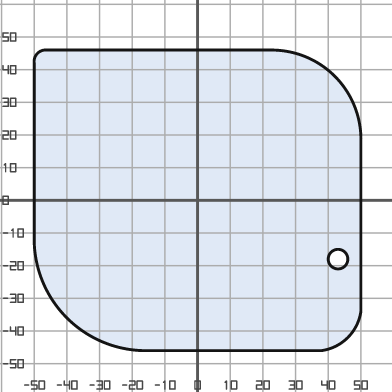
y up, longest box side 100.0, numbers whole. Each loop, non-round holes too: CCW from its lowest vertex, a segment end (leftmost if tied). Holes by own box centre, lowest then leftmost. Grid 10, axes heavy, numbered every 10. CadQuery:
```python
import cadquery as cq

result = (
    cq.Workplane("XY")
    .moveTo(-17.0, -46.0)
    .lineTo(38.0, -46.0)
    .threePointArc((46.0, -42.0), (50.0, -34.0))
    .lineTo(50.0, 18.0)
    .threePointArc((42.0, 38.0), (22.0, 46.0))
    .lineTo(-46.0, 46.0)
    .threePointArc((-49.0, 45.0), (-50.0, 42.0))
    .lineTo(-50.0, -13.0)
    .threePointArc((-40.0, -36.0), (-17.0, -46.0))
    .close()
    .moveTo(43.0, -18.0)
    .circle(3.0)
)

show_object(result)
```